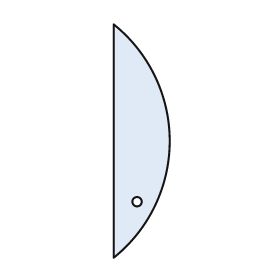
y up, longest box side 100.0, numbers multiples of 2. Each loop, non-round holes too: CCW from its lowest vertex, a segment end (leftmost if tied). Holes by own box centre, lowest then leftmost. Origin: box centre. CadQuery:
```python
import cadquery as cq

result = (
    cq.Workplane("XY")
    .moveTo(-12.0, -50.0)
    .threePointArc((12.0, 0.0), (-12.0, 50.0))
    .close()
    .moveTo(-2.0, -26.0)
    .circle(2.0)
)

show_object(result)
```